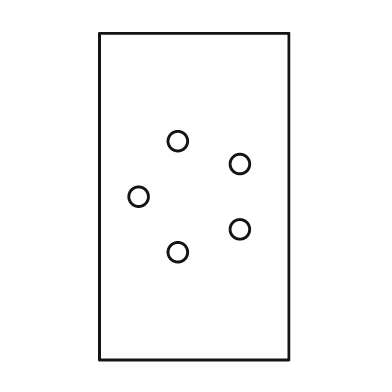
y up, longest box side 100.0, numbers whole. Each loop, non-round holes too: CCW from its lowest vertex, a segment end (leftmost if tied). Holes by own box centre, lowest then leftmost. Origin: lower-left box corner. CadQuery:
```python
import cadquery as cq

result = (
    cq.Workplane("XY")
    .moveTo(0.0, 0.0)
    .lineTo(58.0, 0.0)
    .lineTo(58.0, 100.0)
    .lineTo(0.0, 100.0)
    .close()
    .moveTo(24.0, 33.0)
    .circle(3.0)
    .moveTo(43.0, 40.0)
    .circle(3.0)
    .moveTo(12.0, 50.0)
    .circle(3.0)
    .moveTo(43.0, 60.0)
    .circle(3.0)
    .moveTo(24.0, 67.0)
    .circle(3.0)
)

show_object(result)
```